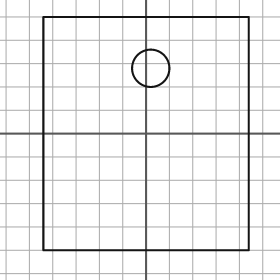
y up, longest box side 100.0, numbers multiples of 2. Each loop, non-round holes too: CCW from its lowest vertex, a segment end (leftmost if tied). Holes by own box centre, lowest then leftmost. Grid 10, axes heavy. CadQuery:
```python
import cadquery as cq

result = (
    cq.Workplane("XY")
    .moveTo(-44.0, -50.0)
    .lineTo(44.0, -50.0)
    .lineTo(44.0, 50.0)
    .lineTo(-44.0, 50.0)
    .close()
    .moveTo(2.0, 28.0)
    .circle(8.0)
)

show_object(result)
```